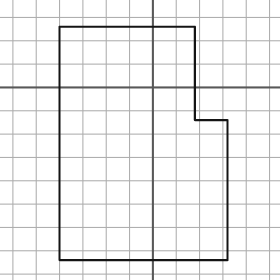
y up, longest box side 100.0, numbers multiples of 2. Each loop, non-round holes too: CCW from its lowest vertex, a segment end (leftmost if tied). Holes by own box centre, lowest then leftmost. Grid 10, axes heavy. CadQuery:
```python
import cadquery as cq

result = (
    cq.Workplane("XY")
    .moveTo(-40.0, -74.0)
    .lineTo(32.0, -74.0)
    .lineTo(32.0, -14.0)
    .lineTo(18.0, -14.0)
    .lineTo(18.0, 26.0)
    .lineTo(-40.0, 26.0)
    .close()
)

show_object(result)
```